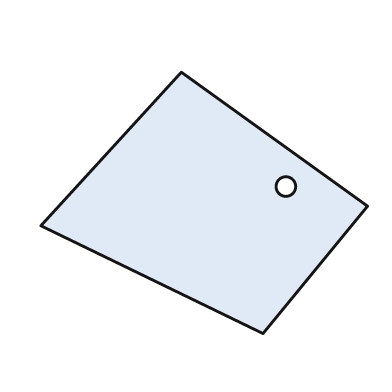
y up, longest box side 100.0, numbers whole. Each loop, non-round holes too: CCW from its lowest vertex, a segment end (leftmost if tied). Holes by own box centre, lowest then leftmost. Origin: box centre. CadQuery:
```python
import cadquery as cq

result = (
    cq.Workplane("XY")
    .moveTo(18.0, -40.0)
    .lineTo(50.0, -1.0)
    .lineTo(-7.0, 40.0)
    .lineTo(-50.0, -7.0)
    .close()
    .moveTo(25.0, 5.0)
    .circle(3.0)
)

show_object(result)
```